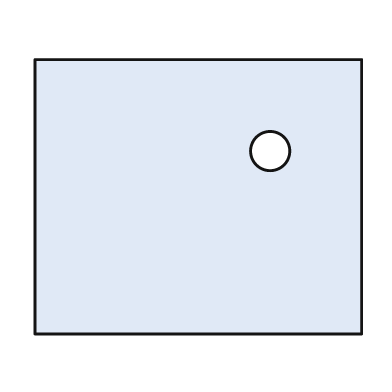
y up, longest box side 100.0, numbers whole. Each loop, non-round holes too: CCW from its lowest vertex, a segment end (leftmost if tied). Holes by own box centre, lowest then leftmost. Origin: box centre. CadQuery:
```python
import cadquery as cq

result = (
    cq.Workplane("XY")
    .moveTo(-50.0, -42.0)
    .lineTo(50.0, -42.0)
    .lineTo(50.0, 42.0)
    .lineTo(-50.0, 42.0)
    .close()
    .moveTo(22.0, 14.0)
    .circle(6.0)
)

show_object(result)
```